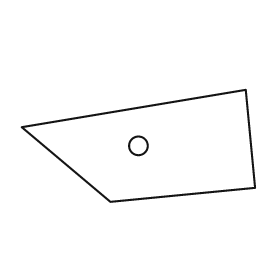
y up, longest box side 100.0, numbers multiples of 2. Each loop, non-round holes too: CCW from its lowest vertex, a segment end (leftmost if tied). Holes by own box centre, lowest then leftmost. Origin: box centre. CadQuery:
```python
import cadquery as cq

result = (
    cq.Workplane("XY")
    .moveTo(-12.0, -24.0)
    .lineTo(50.0, -18.0)
    .lineTo(46.0, 24.0)
    .lineTo(-50.0, 8.0)
    .close()
    .moveTo(0.0, 0.0)
    .circle(4.0)
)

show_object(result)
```